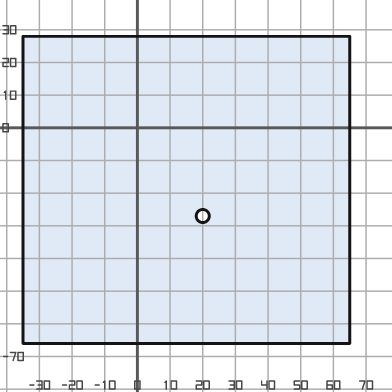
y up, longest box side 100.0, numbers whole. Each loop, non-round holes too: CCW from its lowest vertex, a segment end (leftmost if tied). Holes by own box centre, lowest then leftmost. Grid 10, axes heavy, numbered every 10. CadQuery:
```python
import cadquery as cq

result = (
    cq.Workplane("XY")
    .moveTo(-35.0, -66.0)
    .lineTo(65.0, -66.0)
    .lineTo(65.0, 28.0)
    .lineTo(-35.0, 28.0)
    .close()
    .moveTo(20.0, -27.0)
    .circle(2.0)
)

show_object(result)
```